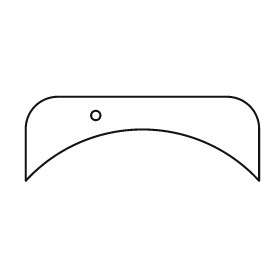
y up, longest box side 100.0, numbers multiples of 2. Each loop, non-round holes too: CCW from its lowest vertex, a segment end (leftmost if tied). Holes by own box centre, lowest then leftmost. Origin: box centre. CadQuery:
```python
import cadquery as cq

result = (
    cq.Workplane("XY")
    .moveTo(-50.0, -18.0)
    .threePointArc((0.0, 4.0), (50.0, -18.0))
    .lineTo(50.0, 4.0)
    .threePointArc((46.0, 14.0), (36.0, 18.0))
    .lineTo(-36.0, 18.0)
    .threePointArc((-46.0, 14.0), (-50.0, 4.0))
    .close()
    .moveTo(-20.0, 10.0)
    .circle(2.0)
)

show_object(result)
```